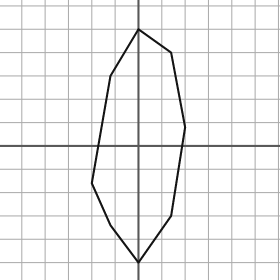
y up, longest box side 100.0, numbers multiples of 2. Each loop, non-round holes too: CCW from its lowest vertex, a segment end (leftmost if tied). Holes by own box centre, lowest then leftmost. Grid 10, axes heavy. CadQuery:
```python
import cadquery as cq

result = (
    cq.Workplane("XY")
    .moveTo(0.0, -50.0)
    .lineTo(14.0, -30.0)
    .lineTo(20.0, 8.0)
    .lineTo(14.0, 40.0)
    .lineTo(0.0, 50.0)
    .lineTo(-12.0, 30.0)
    .lineTo(-20.0, -16.0)
    .lineTo(-12.0, -34.0)
    .close()
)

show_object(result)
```